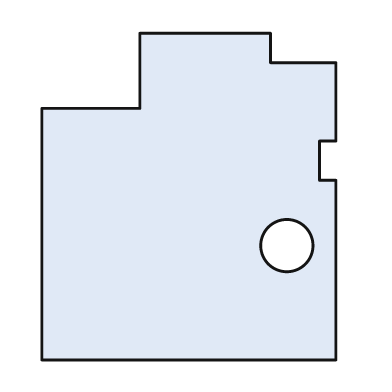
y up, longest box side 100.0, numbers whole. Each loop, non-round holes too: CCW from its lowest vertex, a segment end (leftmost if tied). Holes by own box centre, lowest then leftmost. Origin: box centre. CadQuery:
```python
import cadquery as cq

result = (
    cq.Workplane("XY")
    .moveTo(-45.0, -50.0)
    .lineTo(45.0, -50.0)
    .lineTo(45.0, 5.0)
    .lineTo(40.0, 5.0)
    .lineTo(40.0, 17.0)
    .lineTo(45.0, 17.0)
    .lineTo(45.0, 41.0)
    .lineTo(25.0, 41.0)
    .lineTo(25.0, 50.0)
    .lineTo(-15.0, 50.0)
    .lineTo(-15.0, 27.0)
    .lineTo(-45.0, 27.0)
    .close()
    .moveTo(30.0, -15.0)
    .circle(8.0)
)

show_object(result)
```